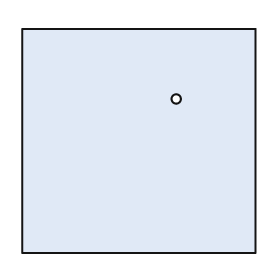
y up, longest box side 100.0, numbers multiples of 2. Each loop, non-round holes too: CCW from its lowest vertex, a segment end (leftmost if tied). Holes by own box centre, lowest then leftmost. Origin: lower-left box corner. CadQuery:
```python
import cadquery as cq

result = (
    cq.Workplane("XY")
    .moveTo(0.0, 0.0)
    .lineTo(100.0, 0.0)
    .lineTo(100.0, 96.0)
    .lineTo(0.0, 96.0)
    .close()
    .moveTo(66.0, 66.0)
    .circle(2.0)
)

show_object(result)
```